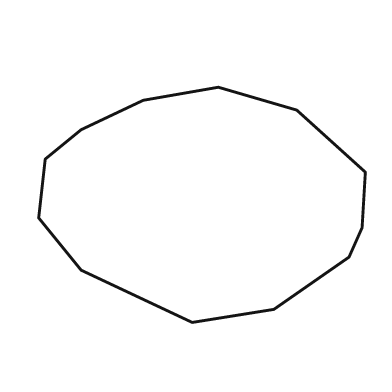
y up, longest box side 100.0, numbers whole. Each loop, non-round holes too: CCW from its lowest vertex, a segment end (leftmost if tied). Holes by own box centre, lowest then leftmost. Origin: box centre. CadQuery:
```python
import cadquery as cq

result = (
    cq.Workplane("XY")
    .moveTo(-3.0, -36.0)
    .lineTo(22.0, -32.0)
    .lineTo(45.0, -16.0)
    .lineTo(49.0, -7.0)
    .lineTo(50.0, 10.0)
    .lineTo(29.0, 29.0)
    .lineTo(5.0, 36.0)
    .lineTo(-18.0, 32.0)
    .lineTo(-37.0, 23.0)
    .lineTo(-48.0, 14.0)
    .lineTo(-50.0, -4.0)
    .lineTo(-37.0, -20.0)
    .close()
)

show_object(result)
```